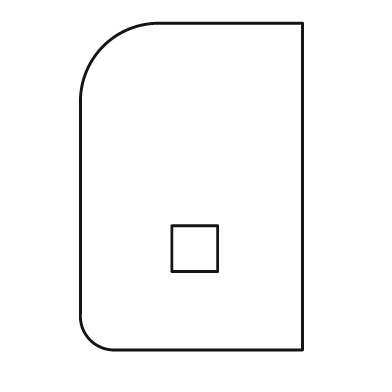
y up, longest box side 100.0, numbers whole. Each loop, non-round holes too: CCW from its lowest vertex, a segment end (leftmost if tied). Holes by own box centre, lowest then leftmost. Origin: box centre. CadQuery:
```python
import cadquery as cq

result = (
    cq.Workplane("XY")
    .moveTo(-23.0, -50.0)
    .lineTo(34.0, -50.0)
    .lineTo(34.0, 50.0)
    .lineTo(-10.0, 50.0)
    .threePointArc((-27.0, 43.0), (-34.0, 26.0))
    .lineTo(-34.0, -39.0)
    .threePointArc((-31.0, -47.0), (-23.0, -50.0))
    .close()
    .moveTo(-6.0, -26.0)
    .lineTo(8.0, -26.0)
    .lineTo(8.0, -12.0)
    .lineTo(-6.0, -12.0)
    .close()
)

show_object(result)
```